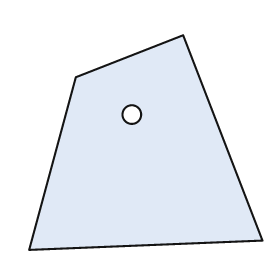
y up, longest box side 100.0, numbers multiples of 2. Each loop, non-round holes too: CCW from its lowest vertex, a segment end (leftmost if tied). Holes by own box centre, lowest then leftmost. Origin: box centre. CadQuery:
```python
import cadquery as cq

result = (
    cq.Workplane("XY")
    .moveTo(-50.0, -46.0)
    .lineTo(50.0, -42.0)
    .lineTo(16.0, 46.0)
    .lineTo(-30.0, 28.0)
    .close()
    .moveTo(-6.0, 12.0)
    .circle(4.0)
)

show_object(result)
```